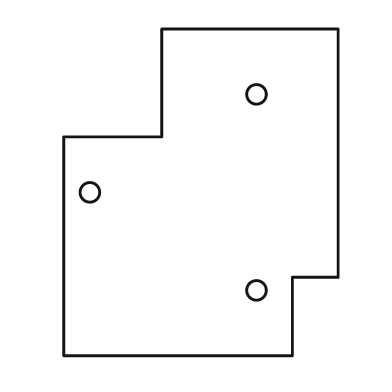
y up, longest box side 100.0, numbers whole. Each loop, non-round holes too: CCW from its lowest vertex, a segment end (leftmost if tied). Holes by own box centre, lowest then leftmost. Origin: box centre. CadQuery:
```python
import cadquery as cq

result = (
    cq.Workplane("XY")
    .moveTo(-42.0, -50.0)
    .lineTo(28.0, -50.0)
    .lineTo(28.0, -26.0)
    .lineTo(42.0, -26.0)
    .lineTo(42.0, 50.0)
    .lineTo(-12.0, 50.0)
    .lineTo(-12.0, 17.0)
    .lineTo(-42.0, 17.0)
    .close()
    .moveTo(17.0, -30.0)
    .circle(3.0)
    .moveTo(-34.0, 0.0)
    .circle(3.0)
    .moveTo(17.0, 30.0)
    .circle(3.0)
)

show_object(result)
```